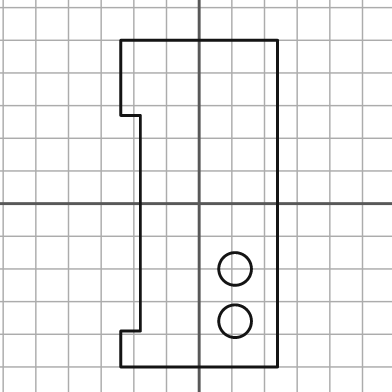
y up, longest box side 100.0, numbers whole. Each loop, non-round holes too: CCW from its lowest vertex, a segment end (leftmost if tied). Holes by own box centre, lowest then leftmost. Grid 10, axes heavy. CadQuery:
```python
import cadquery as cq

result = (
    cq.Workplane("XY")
    .moveTo(-24.0, -50.0)
    .lineTo(24.0, -50.0)
    .lineTo(24.0, 50.0)
    .lineTo(-24.0, 50.0)
    .lineTo(-24.0, 27.0)
    .lineTo(-18.0, 27.0)
    .lineTo(-18.0, -39.0)
    .lineTo(-24.0, -39.0)
    .close()
    .moveTo(11.0, -36.0)
    .circle(5.0)
    .moveTo(11.0, -20.0)
    .circle(5.0)
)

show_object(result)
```